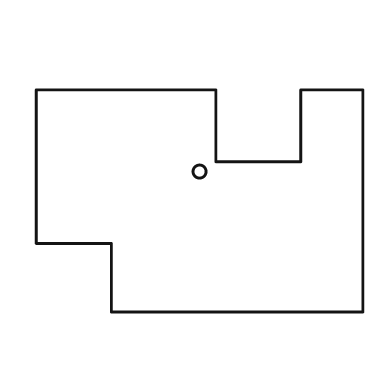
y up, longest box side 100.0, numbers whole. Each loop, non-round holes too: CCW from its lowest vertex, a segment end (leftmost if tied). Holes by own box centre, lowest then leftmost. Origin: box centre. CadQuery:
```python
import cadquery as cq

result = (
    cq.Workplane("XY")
    .moveTo(-27.0, -34.0)
    .lineTo(50.0, -34.0)
    .lineTo(50.0, 34.0)
    .lineTo(31.0, 34.0)
    .lineTo(31.0, 12.0)
    .lineTo(5.0, 12.0)
    .lineTo(5.0, 34.0)
    .lineTo(-50.0, 34.0)
    .lineTo(-50.0, -13.0)
    .lineTo(-27.0, -13.0)
    .close()
    .moveTo(0.0, 9.0)
    .circle(2.0)
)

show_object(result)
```